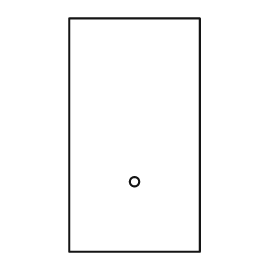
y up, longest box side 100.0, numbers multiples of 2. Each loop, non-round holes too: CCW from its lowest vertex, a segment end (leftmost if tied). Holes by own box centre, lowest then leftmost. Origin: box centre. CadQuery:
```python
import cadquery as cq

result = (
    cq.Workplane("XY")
    .moveTo(-28.0, -50.0)
    .lineTo(28.0, -50.0)
    .lineTo(28.0, 50.0)
    .lineTo(-28.0, 50.0)
    .close()
    .moveTo(0.0, -20.0)
    .circle(2.0)
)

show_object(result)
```